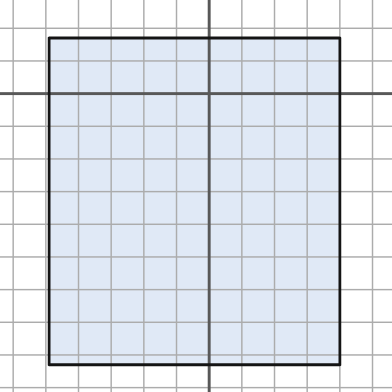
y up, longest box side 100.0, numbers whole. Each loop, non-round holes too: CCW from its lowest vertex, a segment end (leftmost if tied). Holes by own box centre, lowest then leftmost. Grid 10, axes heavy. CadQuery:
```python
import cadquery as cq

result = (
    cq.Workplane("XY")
    .moveTo(-49.0, -83.0)
    .lineTo(40.0, -83.0)
    .lineTo(40.0, 17.0)
    .lineTo(-49.0, 17.0)
    .close()
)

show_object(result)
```